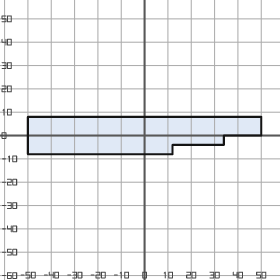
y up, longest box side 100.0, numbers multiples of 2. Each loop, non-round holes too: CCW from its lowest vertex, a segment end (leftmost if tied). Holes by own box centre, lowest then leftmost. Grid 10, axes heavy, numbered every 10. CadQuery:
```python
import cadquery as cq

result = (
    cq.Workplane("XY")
    .moveTo(-50.0, -8.0)
    .lineTo(12.0, -8.0)
    .lineTo(12.0, -4.0)
    .lineTo(34.0, -4.0)
    .lineTo(34.0, 0.0)
    .lineTo(50.0, 0.0)
    .lineTo(50.0, 8.0)
    .lineTo(-50.0, 8.0)
    .close()
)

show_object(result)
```